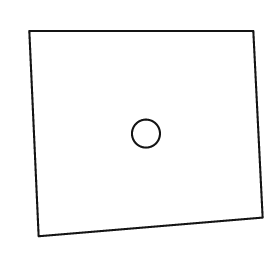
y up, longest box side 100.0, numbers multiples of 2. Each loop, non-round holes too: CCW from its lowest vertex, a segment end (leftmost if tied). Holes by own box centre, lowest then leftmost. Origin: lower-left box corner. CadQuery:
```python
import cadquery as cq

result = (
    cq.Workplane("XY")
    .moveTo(4.0, 0.0)
    .lineTo(100.0, 8.0)
    .lineTo(96.0, 88.0)
    .lineTo(0.0, 88.0)
    .close()
    .moveTo(50.0, 44.0)
    .circle(6.0)
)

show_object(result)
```